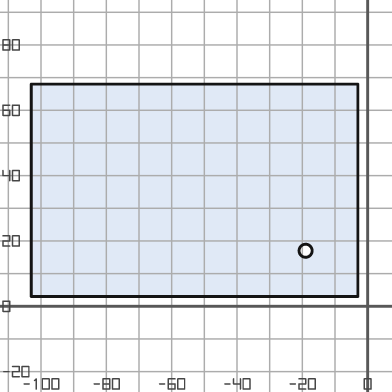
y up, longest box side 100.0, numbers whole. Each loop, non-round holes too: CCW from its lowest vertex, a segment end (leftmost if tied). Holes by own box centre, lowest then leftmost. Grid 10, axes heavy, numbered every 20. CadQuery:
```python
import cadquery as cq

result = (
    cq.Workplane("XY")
    .moveTo(-103.0, 3.0)
    .lineTo(-3.0, 3.0)
    .lineTo(-3.0, 68.0)
    .lineTo(-103.0, 68.0)
    .close()
    .moveTo(-19.0, 17.0)
    .circle(2.0)
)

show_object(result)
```